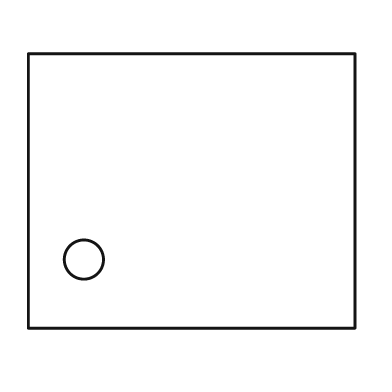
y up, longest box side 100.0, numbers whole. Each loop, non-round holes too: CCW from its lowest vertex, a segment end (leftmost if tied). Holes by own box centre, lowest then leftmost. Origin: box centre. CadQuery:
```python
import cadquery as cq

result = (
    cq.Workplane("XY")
    .moveTo(-50.0, -42.0)
    .lineTo(50.0, -42.0)
    .lineTo(50.0, 42.0)
    .lineTo(-50.0, 42.0)
    .close()
    .moveTo(-33.0, -21.0)
    .circle(6.0)
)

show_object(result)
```